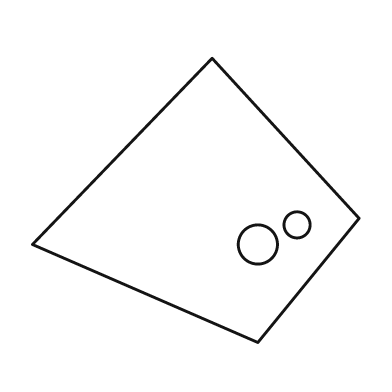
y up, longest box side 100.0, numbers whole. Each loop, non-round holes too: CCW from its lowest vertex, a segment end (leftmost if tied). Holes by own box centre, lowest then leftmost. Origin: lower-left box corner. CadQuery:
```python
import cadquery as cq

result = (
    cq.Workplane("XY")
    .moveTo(69.0, 0.0)
    .lineTo(100.0, 38.0)
    .lineTo(55.0, 87.0)
    .lineTo(0.0, 30.0)
    .close()
    .moveTo(69.0, 30.0)
    .circle(6.0)
    .moveTo(81.0, 36.0)
    .circle(4.0)
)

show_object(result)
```